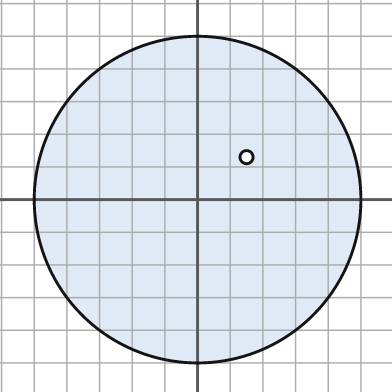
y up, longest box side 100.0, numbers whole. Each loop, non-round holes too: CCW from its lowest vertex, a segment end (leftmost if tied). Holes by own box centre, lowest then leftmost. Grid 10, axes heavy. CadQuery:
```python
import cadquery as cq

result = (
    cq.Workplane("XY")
    .moveTo(0.0, 0.0)
    .circle(50.0)
    .moveTo(15.0, 13.0)
    .circle(2.0)
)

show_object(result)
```